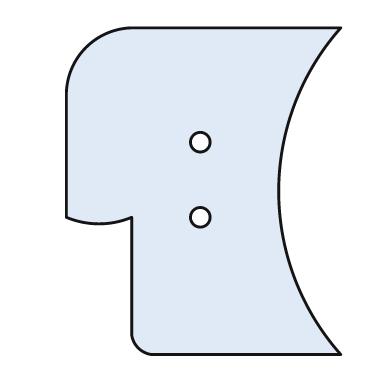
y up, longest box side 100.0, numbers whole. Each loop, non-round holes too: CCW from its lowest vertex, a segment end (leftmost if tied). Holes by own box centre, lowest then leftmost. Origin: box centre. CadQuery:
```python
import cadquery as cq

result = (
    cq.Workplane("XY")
    .moveTo(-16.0, -50.0)
    .lineTo(42.0, -50.0)
    .threePointArc((23.0, 0.0), (42.0, 50.0))
    .lineTo(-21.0, 50.0)
    .threePointArc((-36.0, 44.0), (-42.0, 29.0))
    .lineTo(-42.0, -8.0)
    .threePointArc((-32.0, -10.0), (-22.0, -8.0))
    .lineTo(-22.0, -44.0)
    .threePointArc((-20.0, -48.0), (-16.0, -50.0))
    .close()
    .moveTo(-1.0, -8.0)
    .circle(3.0)
    .moveTo(-1.0, 15.0)
    .circle(3.0)
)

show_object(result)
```